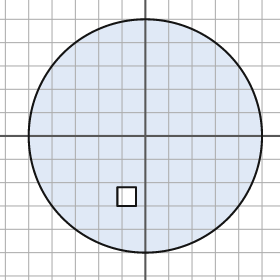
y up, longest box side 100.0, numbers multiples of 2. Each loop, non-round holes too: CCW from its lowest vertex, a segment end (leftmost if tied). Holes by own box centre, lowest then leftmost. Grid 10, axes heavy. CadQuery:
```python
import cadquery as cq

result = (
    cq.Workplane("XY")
    .moveTo(0.0, 0.0)
    .circle(50.0)
    .moveTo(-12.0, -30.0)
    .lineTo(-4.0, -30.0)
    .lineTo(-4.0, -22.0)
    .lineTo(-12.0, -22.0)
    .close()
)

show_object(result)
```